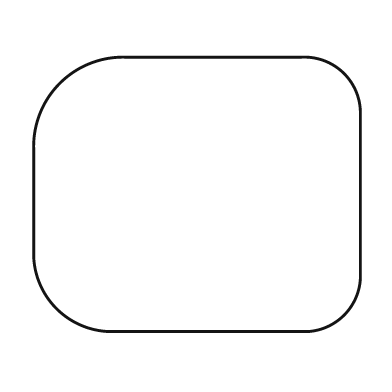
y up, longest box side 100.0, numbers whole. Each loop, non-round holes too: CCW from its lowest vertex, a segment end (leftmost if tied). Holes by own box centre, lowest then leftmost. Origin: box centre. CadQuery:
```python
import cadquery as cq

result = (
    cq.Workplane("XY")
    .moveTo(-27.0, -42.0)
    .lineTo(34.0, -42.0)
    .threePointArc((45.0, -37.0), (50.0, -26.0))
    .lineTo(50.0, 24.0)
    .threePointArc((45.0, 37.0), (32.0, 42.0))
    .lineTo(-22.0, 42.0)
    .threePointArc((-42.0, 34.0), (-50.0, 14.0))
    .lineTo(-50.0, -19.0)
    .threePointArc((-43.0, -35.0), (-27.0, -42.0))
    .close()
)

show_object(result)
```